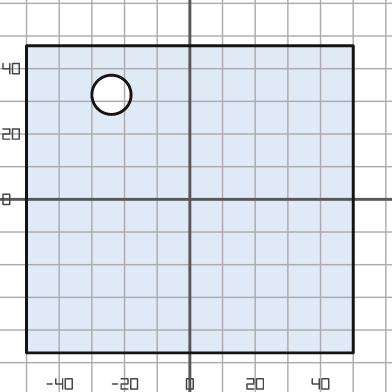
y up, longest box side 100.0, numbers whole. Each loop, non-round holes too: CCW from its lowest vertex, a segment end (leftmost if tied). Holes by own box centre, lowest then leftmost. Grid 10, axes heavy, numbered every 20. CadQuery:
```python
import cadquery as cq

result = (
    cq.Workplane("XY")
    .moveTo(-50.0, -47.0)
    .lineTo(50.0, -47.0)
    .lineTo(50.0, 47.0)
    .lineTo(-50.0, 47.0)
    .close()
    .moveTo(-24.0, 32.0)
    .circle(6.0)
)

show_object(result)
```